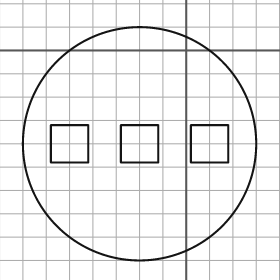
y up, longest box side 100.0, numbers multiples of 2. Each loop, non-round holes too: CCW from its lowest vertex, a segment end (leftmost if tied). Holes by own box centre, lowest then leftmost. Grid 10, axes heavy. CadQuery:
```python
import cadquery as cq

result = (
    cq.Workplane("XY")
    .moveTo(-20.0, -40.0)
    .circle(50.0)
    .moveTo(-58.0, -48.0)
    .lineTo(-42.0, -48.0)
    .lineTo(-42.0, -32.0)
    .lineTo(-58.0, -32.0)
    .close()
    .moveTo(-28.0, -48.0)
    .lineTo(-12.0, -48.0)
    .lineTo(-12.0, -32.0)
    .lineTo(-28.0, -32.0)
    .close()
    .moveTo(2.0, -48.0)
    .lineTo(18.0, -48.0)
    .lineTo(18.0, -32.0)
    .lineTo(2.0, -32.0)
    .close()
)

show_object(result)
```